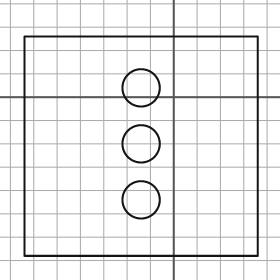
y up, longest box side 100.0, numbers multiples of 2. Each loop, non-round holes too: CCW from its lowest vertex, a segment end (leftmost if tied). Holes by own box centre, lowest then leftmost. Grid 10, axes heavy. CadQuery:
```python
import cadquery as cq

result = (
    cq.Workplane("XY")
    .moveTo(-64.0, -68.0)
    .lineTo(36.0, -68.0)
    .lineTo(36.0, 26.0)
    .lineTo(-64.0, 26.0)
    .close()
    .moveTo(-14.0, -44.0)
    .circle(8.0)
    .moveTo(-14.0, -20.0)
    .circle(8.0)
    .moveTo(-14.0, 4.0)
    .circle(8.0)
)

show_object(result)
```